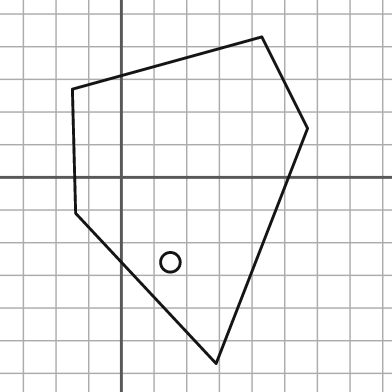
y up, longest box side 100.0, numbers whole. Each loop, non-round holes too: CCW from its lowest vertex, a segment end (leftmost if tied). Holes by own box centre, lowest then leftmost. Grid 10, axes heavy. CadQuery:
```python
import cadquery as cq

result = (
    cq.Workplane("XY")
    .moveTo(29.0, -57.0)
    .lineTo(57.0, 15.0)
    .lineTo(43.0, 43.0)
    .lineTo(-15.0, 27.0)
    .lineTo(-14.0, -11.0)
    .close()
    .moveTo(15.0, -26.0)
    .circle(3.0)
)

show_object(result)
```